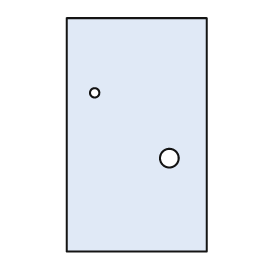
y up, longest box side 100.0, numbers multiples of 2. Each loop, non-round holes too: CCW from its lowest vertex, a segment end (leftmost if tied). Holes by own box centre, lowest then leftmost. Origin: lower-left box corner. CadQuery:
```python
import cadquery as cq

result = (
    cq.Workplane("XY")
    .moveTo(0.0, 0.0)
    .lineTo(60.0, 0.0)
    .lineTo(60.0, 100.0)
    .lineTo(0.0, 100.0)
    .close()
    .moveTo(44.0, 40.0)
    .circle(4.0)
    .moveTo(12.0, 68.0)
    .circle(2.0)
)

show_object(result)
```